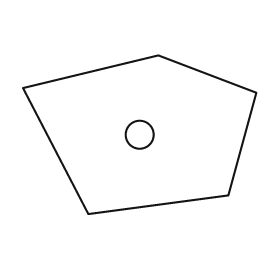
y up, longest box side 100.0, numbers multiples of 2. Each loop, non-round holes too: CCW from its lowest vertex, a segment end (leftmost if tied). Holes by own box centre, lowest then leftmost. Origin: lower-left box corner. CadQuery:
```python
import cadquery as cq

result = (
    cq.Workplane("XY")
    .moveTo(28.0, 0.0)
    .lineTo(88.0, 8.0)
    .lineTo(100.0, 52.0)
    .lineTo(58.0, 68.0)
    .lineTo(0.0, 54.0)
    .close()
    .moveTo(50.0, 34.0)
    .circle(6.0)
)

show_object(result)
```